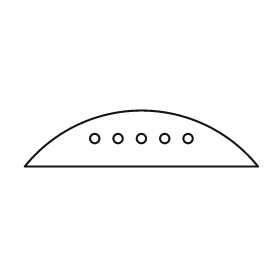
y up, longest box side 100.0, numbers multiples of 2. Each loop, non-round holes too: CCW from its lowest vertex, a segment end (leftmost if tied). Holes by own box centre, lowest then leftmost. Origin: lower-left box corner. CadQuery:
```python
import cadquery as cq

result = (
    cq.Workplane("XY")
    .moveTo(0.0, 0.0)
    .lineTo(100.0, 0.0)
    .threePointArc((50.0, 24.0), (0.0, 0.0))
    .close()
    .moveTo(30.0, 12.0)
    .circle(2.0)
    .moveTo(40.0, 12.0)
    .circle(2.0)
    .moveTo(50.0, 12.0)
    .circle(2.0)
    .moveTo(60.0, 12.0)
    .circle(2.0)
    .moveTo(70.0, 12.0)
    .circle(2.0)
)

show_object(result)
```